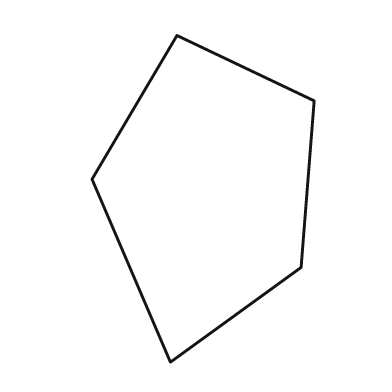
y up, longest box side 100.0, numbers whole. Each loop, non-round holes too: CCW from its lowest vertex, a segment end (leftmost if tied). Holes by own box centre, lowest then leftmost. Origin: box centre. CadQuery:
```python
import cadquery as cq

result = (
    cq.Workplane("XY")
    .moveTo(-10.0, -50.0)
    .lineTo(30.0, -21.0)
    .lineTo(34.0, 30.0)
    .lineTo(-8.0, 50.0)
    .lineTo(-34.0, 6.0)
    .close()
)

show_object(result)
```